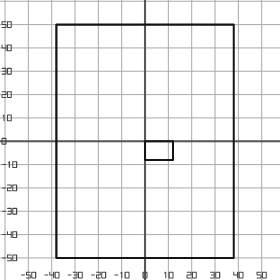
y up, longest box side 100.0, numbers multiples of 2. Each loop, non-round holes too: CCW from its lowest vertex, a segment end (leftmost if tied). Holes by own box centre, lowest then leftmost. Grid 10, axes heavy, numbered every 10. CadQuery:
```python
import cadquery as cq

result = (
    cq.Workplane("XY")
    .moveTo(-38.0, -50.0)
    .lineTo(38.0, -50.0)
    .lineTo(38.0, 50.0)
    .lineTo(-38.0, 50.0)
    .close()
    .moveTo(0.0, -8.0)
    .lineTo(12.0, -8.0)
    .lineTo(12.0, 0.0)
    .lineTo(0.0, 0.0)
    .close()
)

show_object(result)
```